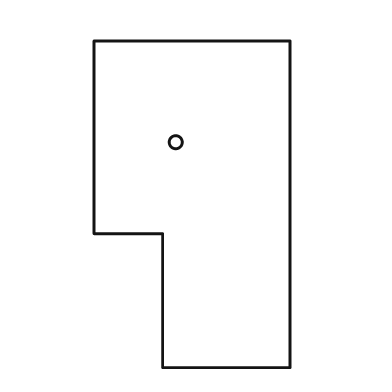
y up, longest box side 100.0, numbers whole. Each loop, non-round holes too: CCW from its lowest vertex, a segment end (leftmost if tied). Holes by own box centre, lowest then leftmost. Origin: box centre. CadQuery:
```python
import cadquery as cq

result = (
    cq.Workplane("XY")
    .moveTo(-9.0, -50.0)
    .lineTo(30.0, -50.0)
    .lineTo(30.0, 50.0)
    .lineTo(-30.0, 50.0)
    .lineTo(-30.0, -9.0)
    .lineTo(-9.0, -9.0)
    .close()
    .moveTo(-5.0, 19.0)
    .circle(2.0)
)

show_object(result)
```